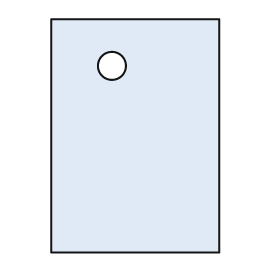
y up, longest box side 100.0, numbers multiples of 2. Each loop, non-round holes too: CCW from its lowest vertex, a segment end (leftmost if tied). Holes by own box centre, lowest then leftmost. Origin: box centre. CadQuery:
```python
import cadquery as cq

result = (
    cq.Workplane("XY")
    .moveTo(-36.0, -50.0)
    .lineTo(36.0, -50.0)
    .lineTo(36.0, 50.0)
    .lineTo(-36.0, 50.0)
    .close()
    .moveTo(-10.0, 30.0)
    .circle(6.0)
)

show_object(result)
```